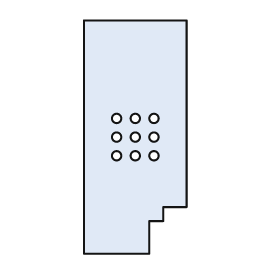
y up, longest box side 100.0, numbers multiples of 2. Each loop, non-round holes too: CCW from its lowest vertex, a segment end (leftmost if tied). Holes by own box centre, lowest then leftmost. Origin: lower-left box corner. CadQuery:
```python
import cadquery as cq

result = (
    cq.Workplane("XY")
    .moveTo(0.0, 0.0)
    .lineTo(28.0, 0.0)
    .lineTo(28.0, 14.0)
    .lineTo(34.0, 14.0)
    .lineTo(34.0, 20.0)
    .lineTo(44.0, 20.0)
    .lineTo(44.0, 100.0)
    .lineTo(0.0, 100.0)
    .close()
    .moveTo(14.0, 42.0)
    .circle(2.0)
    .moveTo(22.0, 42.0)
    .circle(2.0)
    .moveTo(30.0, 42.0)
    .circle(2.0)
    .moveTo(14.0, 50.0)
    .circle(2.0)
    .moveTo(22.0, 50.0)
    .circle(2.0)
    .moveTo(30.0, 50.0)
    .circle(2.0)
    .moveTo(14.0, 58.0)
    .circle(2.0)
    .moveTo(22.0, 58.0)
    .circle(2.0)
    .moveTo(30.0, 58.0)
    .circle(2.0)
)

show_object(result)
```